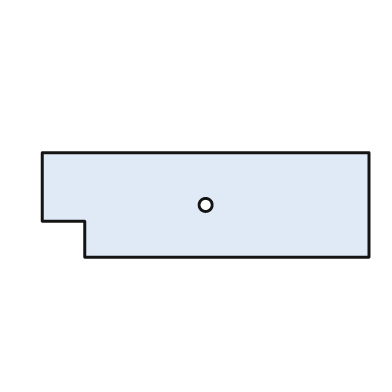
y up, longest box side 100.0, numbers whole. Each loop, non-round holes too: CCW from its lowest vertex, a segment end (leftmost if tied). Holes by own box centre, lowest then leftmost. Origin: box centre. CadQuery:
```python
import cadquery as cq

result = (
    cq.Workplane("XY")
    .moveTo(-37.0, -16.0)
    .lineTo(50.0, -16.0)
    .lineTo(50.0, 16.0)
    .lineTo(-50.0, 16.0)
    .lineTo(-50.0, -5.0)
    .lineTo(-37.0, -5.0)
    .close()
    .moveTo(0.0, 0.0)
    .circle(2.0)
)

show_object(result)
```